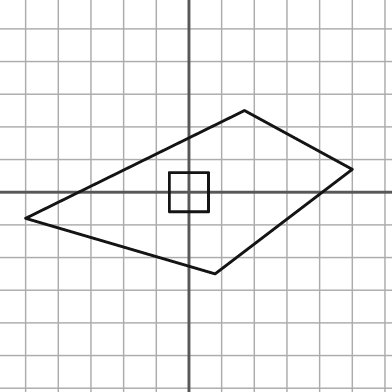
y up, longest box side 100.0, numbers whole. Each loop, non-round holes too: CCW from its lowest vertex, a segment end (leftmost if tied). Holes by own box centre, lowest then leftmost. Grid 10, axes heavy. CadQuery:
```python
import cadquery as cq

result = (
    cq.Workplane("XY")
    .moveTo(8.0, -25.0)
    .lineTo(50.0, 7.0)
    .lineTo(17.0, 25.0)
    .lineTo(-50.0, -8.0)
    .close()
    .moveTo(-6.0, -6.0)
    .lineTo(6.0, -6.0)
    .lineTo(6.0, 6.0)
    .lineTo(-6.0, 6.0)
    .close()
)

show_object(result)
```